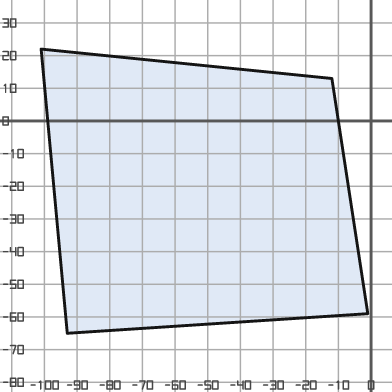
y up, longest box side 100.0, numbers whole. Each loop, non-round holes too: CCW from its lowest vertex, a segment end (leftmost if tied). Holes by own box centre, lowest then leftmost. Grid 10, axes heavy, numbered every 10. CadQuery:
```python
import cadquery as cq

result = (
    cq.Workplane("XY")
    .moveTo(-93.0, -65.0)
    .lineTo(-1.0, -59.0)
    .lineTo(-12.0, 13.0)
    .lineTo(-101.0, 22.0)
    .close()
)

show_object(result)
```